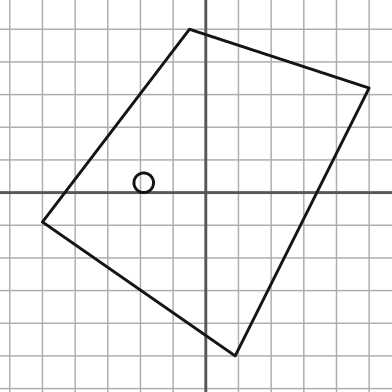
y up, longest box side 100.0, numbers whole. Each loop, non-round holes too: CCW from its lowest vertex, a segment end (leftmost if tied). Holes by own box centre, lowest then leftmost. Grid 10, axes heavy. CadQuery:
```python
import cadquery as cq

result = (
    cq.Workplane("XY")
    .moveTo(9.0, -50.0)
    .lineTo(50.0, 32.0)
    .lineTo(-5.0, 50.0)
    .lineTo(-50.0, -9.0)
    .close()
    .moveTo(-19.0, 3.0)
    .circle(3.0)
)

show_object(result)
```